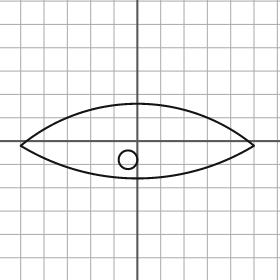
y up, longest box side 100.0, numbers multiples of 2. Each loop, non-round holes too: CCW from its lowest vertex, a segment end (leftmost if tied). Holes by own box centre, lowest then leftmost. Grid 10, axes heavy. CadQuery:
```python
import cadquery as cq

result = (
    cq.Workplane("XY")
    .moveTo(-50.0, -2.0)
    .threePointArc((0.0, -16.0), (50.0, -2.0))
    .threePointArc((0.0, 16.0), (-50.0, -2.0))
    .close()
    .moveTo(-4.0, -8.0)
    .circle(4.0)
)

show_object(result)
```